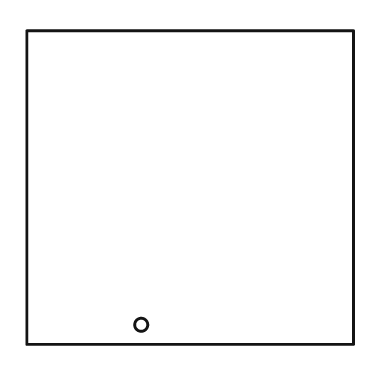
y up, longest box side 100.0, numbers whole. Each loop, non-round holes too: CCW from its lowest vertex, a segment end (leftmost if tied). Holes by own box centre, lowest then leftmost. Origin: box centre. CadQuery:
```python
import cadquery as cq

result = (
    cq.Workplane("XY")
    .moveTo(-50.0, -48.0)
    .lineTo(50.0, -48.0)
    .lineTo(50.0, 48.0)
    .lineTo(-50.0, 48.0)
    .close()
    .moveTo(-15.0, -42.0)
    .circle(2.0)
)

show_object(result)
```